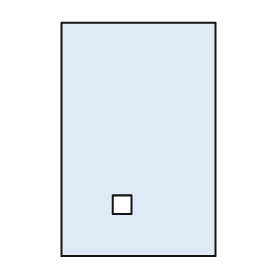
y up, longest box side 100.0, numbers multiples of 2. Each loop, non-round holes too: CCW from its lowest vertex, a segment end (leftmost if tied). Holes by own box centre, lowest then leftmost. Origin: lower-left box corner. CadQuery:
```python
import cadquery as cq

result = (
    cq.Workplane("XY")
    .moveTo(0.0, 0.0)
    .lineTo(66.0, 0.0)
    .lineTo(66.0, 100.0)
    .lineTo(0.0, 100.0)
    .close()
    .moveTo(22.0, 18.0)
    .lineTo(30.0, 18.0)
    .lineTo(30.0, 26.0)
    .lineTo(22.0, 26.0)
    .close()
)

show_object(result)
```